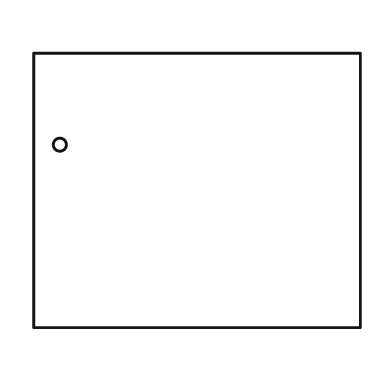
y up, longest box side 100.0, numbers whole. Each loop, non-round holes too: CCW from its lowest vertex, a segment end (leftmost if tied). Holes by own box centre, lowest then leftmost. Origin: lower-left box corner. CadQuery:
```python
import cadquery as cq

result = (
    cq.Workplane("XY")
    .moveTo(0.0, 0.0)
    .lineTo(100.0, 0.0)
    .lineTo(100.0, 84.0)
    .lineTo(0.0, 84.0)
    .close()
    .moveTo(8.0, 56.0)
    .circle(2.0)
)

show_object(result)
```